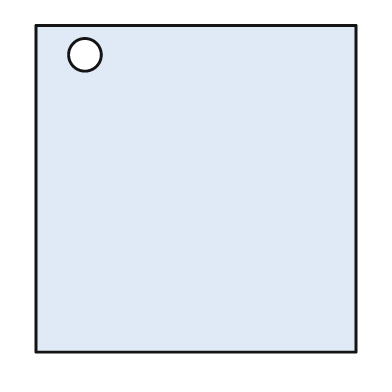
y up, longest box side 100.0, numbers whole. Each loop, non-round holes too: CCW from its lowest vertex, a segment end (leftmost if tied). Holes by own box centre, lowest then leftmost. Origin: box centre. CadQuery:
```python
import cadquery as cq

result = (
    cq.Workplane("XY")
    .moveTo(-49.0, -50.0)
    .lineTo(49.0, -50.0)
    .lineTo(49.0, 50.0)
    .lineTo(-49.0, 50.0)
    .close()
    .moveTo(-34.0, 41.0)
    .circle(5.0)
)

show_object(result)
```